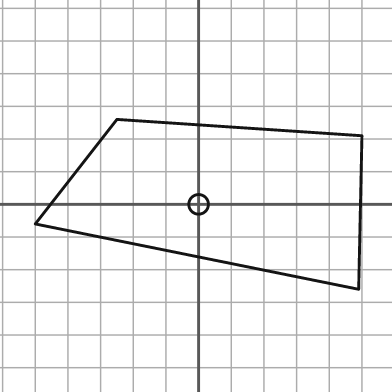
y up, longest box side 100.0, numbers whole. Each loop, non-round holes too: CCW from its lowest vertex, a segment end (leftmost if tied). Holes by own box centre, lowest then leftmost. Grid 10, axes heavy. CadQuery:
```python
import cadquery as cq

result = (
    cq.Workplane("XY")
    .moveTo(49.0, -26.0)
    .lineTo(50.0, 21.0)
    .lineTo(-25.0, 26.0)
    .lineTo(-50.0, -6.0)
    .close()
    .moveTo(0.0, 0.0)
    .circle(3.0)
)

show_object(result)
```